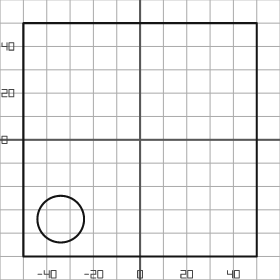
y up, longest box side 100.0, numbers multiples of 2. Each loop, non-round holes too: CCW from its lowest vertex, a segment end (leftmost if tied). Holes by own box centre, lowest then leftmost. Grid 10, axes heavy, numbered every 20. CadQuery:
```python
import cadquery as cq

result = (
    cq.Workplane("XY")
    .moveTo(-50.0, -50.0)
    .lineTo(50.0, -50.0)
    .lineTo(50.0, 50.0)
    .lineTo(-50.0, 50.0)
    .close()
    .moveTo(-34.0, -34.0)
    .circle(10.0)
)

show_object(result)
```